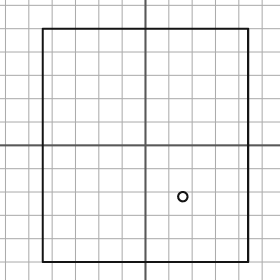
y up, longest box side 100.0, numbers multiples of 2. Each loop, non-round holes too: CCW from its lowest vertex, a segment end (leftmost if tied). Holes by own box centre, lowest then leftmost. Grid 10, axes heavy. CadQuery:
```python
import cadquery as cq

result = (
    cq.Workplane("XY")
    .moveTo(-44.0, -50.0)
    .lineTo(44.0, -50.0)
    .lineTo(44.0, 50.0)
    .lineTo(-44.0, 50.0)
    .close()
    .moveTo(16.0, -22.0)
    .circle(2.0)
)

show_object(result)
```